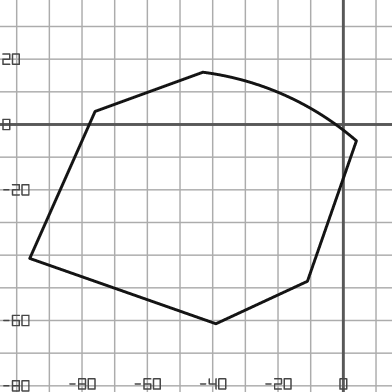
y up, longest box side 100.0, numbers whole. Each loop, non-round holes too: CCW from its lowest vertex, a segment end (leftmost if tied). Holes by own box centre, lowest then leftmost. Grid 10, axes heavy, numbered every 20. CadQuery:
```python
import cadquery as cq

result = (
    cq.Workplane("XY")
    .moveTo(-39.0, -61.0)
    .lineTo(-11.0, -48.0)
    .lineTo(4.0, -5.0)
    .threePointArc((-18.0, 9.0), (-43.0, 16.0))
    .lineTo(-76.0, 4.0)
    .lineTo(-96.0, -41.0)
    .close()
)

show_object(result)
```